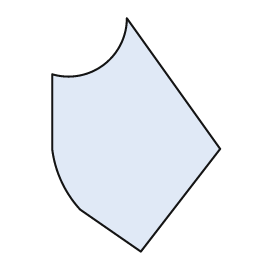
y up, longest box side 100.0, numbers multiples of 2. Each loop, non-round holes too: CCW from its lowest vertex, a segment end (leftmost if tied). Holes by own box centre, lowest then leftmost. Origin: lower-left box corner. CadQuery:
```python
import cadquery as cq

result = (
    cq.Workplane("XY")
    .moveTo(38.0, 0.0)
    .lineTo(72.0, 44.0)
    .lineTo(32.0, 100.0)
    .threePointArc((22.0, 80.0), (0.0, 76.0))
    .lineTo(0.0, 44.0)
    .threePointArc((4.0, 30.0), (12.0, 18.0))
    .close()
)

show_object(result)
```